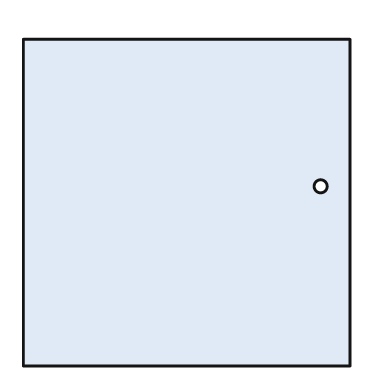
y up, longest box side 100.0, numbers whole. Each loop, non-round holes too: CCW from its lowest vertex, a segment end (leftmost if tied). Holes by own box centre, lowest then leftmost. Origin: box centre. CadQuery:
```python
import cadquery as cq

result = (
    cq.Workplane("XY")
    .moveTo(-50.0, -50.0)
    .lineTo(50.0, -50.0)
    .lineTo(50.0, 50.0)
    .lineTo(-50.0, 50.0)
    .close()
    .moveTo(41.0, 5.0)
    .circle(2.0)
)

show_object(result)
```